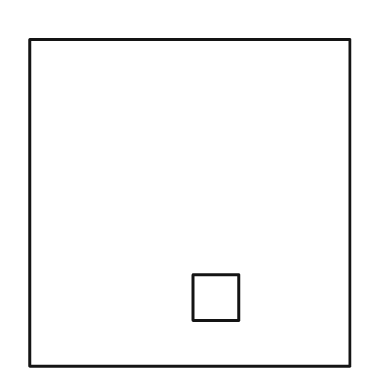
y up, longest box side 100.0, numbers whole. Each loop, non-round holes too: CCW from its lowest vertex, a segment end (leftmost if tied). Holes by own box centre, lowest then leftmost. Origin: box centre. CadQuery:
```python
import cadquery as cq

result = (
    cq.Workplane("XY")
    .moveTo(-49.0, -50.0)
    .lineTo(49.0, -50.0)
    .lineTo(49.0, 50.0)
    .lineTo(-49.0, 50.0)
    .close()
    .moveTo(1.0, -36.0)
    .lineTo(15.0, -36.0)
    .lineTo(15.0, -22.0)
    .lineTo(1.0, -22.0)
    .close()
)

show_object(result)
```